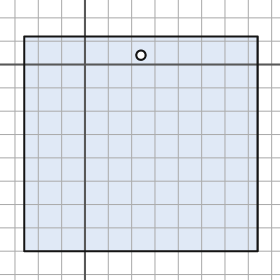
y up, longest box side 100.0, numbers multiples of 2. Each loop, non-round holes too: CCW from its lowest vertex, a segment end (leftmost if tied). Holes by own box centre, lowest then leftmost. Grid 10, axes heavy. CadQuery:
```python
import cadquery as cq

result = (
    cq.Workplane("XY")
    .moveTo(-26.0, -80.0)
    .lineTo(74.0, -80.0)
    .lineTo(74.0, 12.0)
    .lineTo(-26.0, 12.0)
    .close()
    .moveTo(24.0, 4.0)
    .circle(2.0)
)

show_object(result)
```